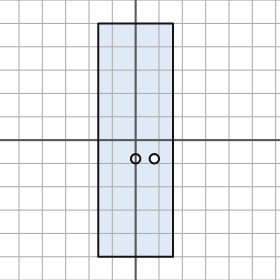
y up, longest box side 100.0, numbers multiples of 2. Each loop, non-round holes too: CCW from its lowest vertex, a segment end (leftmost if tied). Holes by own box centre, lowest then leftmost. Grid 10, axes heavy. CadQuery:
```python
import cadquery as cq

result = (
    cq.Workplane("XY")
    .moveTo(-16.0, -50.0)
    .lineTo(16.0, -50.0)
    .lineTo(16.0, 50.0)
    .lineTo(-16.0, 50.0)
    .close()
    .moveTo(0.0, -8.0)
    .circle(2.0)
    .moveTo(8.0, -8.0)
    .circle(2.0)
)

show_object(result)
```